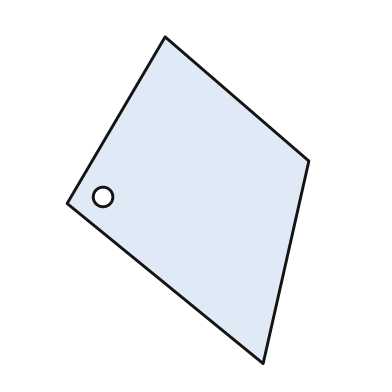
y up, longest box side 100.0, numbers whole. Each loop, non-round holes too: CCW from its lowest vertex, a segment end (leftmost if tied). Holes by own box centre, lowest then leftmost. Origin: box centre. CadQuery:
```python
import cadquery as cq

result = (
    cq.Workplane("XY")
    .moveTo(23.0, -50.0)
    .lineTo(37.0, 12.0)
    .lineTo(-7.0, 50.0)
    .lineTo(-37.0, -1.0)
    .close()
    .moveTo(-26.0, 1.0)
    .circle(3.0)
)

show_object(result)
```